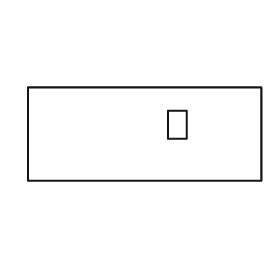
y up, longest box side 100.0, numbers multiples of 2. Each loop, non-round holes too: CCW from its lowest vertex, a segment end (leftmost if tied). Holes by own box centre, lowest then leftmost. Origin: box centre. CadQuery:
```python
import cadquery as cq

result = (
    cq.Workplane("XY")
    .moveTo(-50.0, -20.0)
    .lineTo(50.0, -20.0)
    .lineTo(50.0, 20.0)
    .lineTo(-50.0, 20.0)
    .close()
    .moveTo(10.0, -2.0)
    .lineTo(18.0, -2.0)
    .lineTo(18.0, 10.0)
    .lineTo(10.0, 10.0)
    .close()
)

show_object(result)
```